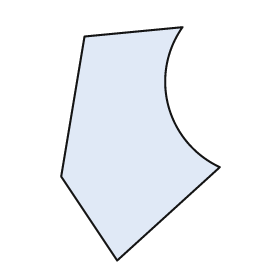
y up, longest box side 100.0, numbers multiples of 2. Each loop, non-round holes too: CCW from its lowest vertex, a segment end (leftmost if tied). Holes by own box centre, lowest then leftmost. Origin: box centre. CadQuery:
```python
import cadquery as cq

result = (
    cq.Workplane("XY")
    .moveTo(-10.0, -50.0)
    .lineTo(34.0, -10.0)
    .threePointArc((12.0, 16.0), (18.0, 50.0))
    .lineTo(-24.0, 46.0)
    .lineTo(-34.0, -14.0)
    .close()
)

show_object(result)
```